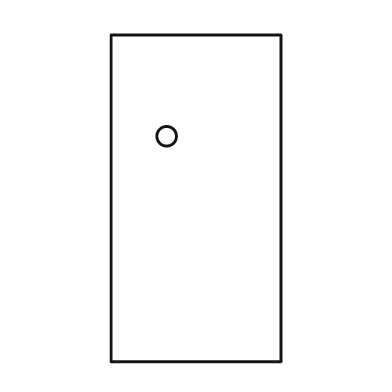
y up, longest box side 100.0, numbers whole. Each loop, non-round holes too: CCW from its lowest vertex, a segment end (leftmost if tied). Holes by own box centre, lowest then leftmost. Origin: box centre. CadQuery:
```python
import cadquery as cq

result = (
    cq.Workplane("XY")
    .moveTo(-26.0, -50.0)
    .lineTo(26.0, -50.0)
    .lineTo(26.0, 50.0)
    .lineTo(-26.0, 50.0)
    .close()
    .moveTo(-9.0, 19.0)
    .circle(3.0)
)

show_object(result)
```